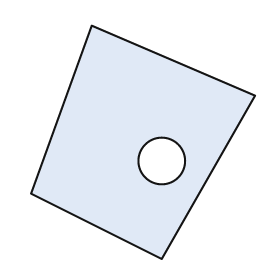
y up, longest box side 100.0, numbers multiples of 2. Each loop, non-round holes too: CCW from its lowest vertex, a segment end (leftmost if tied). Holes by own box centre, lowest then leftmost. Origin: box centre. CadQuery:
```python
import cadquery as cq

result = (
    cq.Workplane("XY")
    .moveTo(8.0, -50.0)
    .lineTo(48.0, 20.0)
    .lineTo(-22.0, 50.0)
    .lineTo(-48.0, -22.0)
    .close()
    .moveTo(8.0, -8.0)
    .circle(10.0)
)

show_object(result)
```